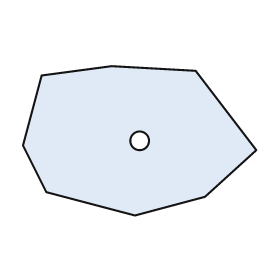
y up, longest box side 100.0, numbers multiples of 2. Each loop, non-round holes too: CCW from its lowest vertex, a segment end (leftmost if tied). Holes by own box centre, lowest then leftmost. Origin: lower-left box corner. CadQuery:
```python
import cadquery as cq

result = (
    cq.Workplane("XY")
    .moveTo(48.0, 0.0)
    .lineTo(78.0, 8.0)
    .lineTo(100.0, 28.0)
    .lineTo(74.0, 62.0)
    .lineTo(38.0, 64.0)
    .lineTo(8.0, 60.0)
    .lineTo(0.0, 30.0)
    .lineTo(10.0, 10.0)
    .close()
    .moveTo(50.0, 32.0)
    .circle(4.0)
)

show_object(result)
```